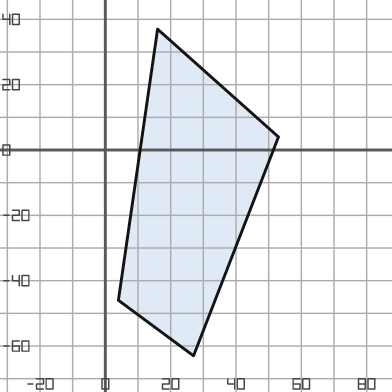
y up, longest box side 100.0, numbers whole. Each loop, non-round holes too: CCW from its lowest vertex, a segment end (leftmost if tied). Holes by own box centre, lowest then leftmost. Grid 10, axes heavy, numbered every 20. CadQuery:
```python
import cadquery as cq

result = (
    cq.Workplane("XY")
    .moveTo(27.0, -63.0)
    .lineTo(53.0, 4.0)
    .lineTo(16.0, 37.0)
    .lineTo(4.0, -46.0)
    .close()
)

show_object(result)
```